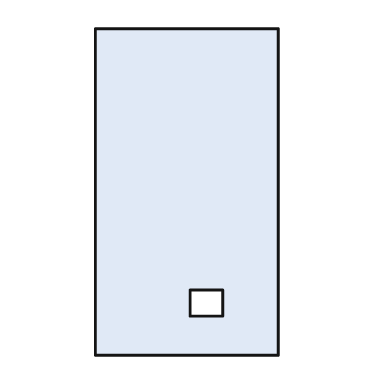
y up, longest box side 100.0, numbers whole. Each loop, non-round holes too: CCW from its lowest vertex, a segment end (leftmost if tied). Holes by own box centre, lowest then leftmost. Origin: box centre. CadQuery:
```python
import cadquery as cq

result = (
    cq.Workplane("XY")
    .moveTo(-28.0, -50.0)
    .lineTo(28.0, -50.0)
    .lineTo(28.0, 50.0)
    .lineTo(-28.0, 50.0)
    .close()
    .moveTo(1.0, -38.0)
    .lineTo(11.0, -38.0)
    .lineTo(11.0, -30.0)
    .lineTo(1.0, -30.0)
    .close()
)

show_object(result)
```